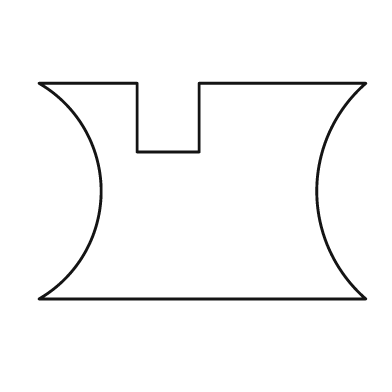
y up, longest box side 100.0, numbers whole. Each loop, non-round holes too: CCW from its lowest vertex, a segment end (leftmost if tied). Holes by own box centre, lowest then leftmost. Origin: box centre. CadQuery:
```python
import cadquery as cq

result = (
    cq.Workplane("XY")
    .moveTo(-50.0, -33.0)
    .lineTo(50.0, -33.0)
    .threePointArc((35.0, 0.0), (50.0, 33.0))
    .lineTo(-1.0, 33.0)
    .lineTo(-1.0, 12.0)
    .lineTo(-20.0, 12.0)
    .lineTo(-20.0, 33.0)
    .lineTo(-50.0, 33.0)
    .threePointArc((-31.0, 0.0), (-50.0, -33.0))
    .close()
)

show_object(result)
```